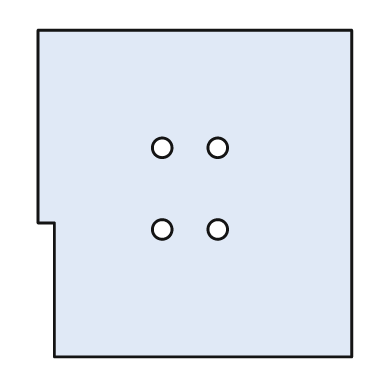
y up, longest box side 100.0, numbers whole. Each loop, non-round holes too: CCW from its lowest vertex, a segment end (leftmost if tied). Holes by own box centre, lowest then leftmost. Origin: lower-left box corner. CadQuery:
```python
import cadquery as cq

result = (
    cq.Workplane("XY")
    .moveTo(5.0, 0.0)
    .lineTo(96.0, 0.0)
    .lineTo(96.0, 100.0)
    .lineTo(0.0, 100.0)
    .lineTo(0.0, 41.0)
    .lineTo(5.0, 41.0)
    .close()
    .moveTo(38.0, 39.0)
    .circle(3.0)
    .moveTo(55.0, 39.0)
    .circle(3.0)
    .moveTo(38.0, 64.0)
    .circle(3.0)
    .moveTo(55.0, 64.0)
    .circle(3.0)
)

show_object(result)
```